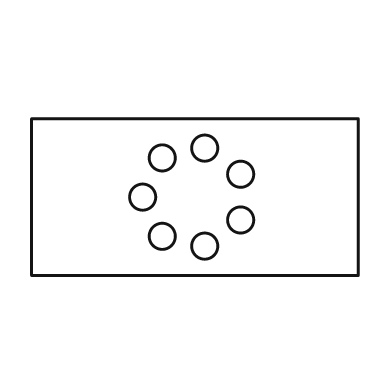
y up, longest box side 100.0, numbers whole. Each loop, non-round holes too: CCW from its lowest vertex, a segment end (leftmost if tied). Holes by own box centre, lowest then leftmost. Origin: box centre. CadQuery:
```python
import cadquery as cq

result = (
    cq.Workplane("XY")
    .moveTo(-50.0, -24.0)
    .lineTo(50.0, -24.0)
    .lineTo(50.0, 24.0)
    .lineTo(-50.0, 24.0)
    .close()
    .moveTo(3.0, -15.0)
    .circle(4.0)
    .moveTo(-10.0, -12.0)
    .circle(4.0)
    .moveTo(14.0, -7.0)
    .circle(4.0)
    .moveTo(-16.0, 0.0)
    .circle(4.0)
    .moveTo(14.0, 7.0)
    .circle(4.0)
    .moveTo(-10.0, 12.0)
    .circle(4.0)
    .moveTo(3.0, 15.0)
    .circle(4.0)
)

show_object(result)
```